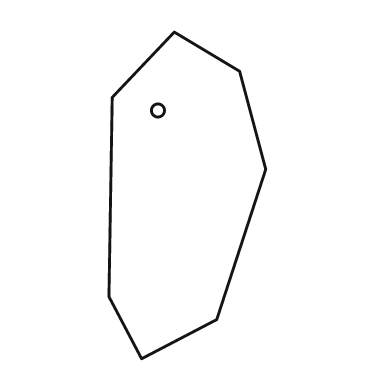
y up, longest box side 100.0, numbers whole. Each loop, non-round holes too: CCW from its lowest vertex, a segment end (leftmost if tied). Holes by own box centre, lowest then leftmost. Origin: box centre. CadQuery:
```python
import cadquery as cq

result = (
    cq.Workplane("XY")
    .moveTo(-14.0, -50.0)
    .lineTo(9.0, -38.0)
    .lineTo(24.0, 8.0)
    .lineTo(16.0, 38.0)
    .lineTo(-4.0, 50.0)
    .lineTo(-23.0, 30.0)
    .lineTo(-24.0, -31.0)
    .close()
    .moveTo(-9.0, 26.0)
    .circle(2.0)
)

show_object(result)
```